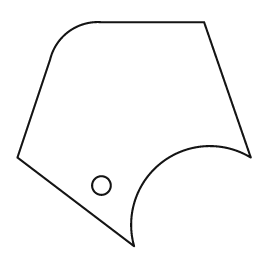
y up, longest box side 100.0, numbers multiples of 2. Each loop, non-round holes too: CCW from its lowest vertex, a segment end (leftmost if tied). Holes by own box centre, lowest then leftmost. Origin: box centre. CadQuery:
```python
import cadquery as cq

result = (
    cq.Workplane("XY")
    .moveTo(0.0, -48.0)
    .threePointArc((12.0, -12.0), (50.0, -10.0))
    .lineTo(30.0, 48.0)
    .lineTo(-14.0, 48.0)
    .threePointArc((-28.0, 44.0), (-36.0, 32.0))
    .lineTo(-50.0, -10.0)
    .close()
    .moveTo(-14.0, -22.0)
    .circle(4.0)
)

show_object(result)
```